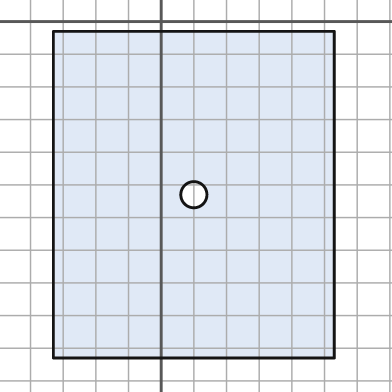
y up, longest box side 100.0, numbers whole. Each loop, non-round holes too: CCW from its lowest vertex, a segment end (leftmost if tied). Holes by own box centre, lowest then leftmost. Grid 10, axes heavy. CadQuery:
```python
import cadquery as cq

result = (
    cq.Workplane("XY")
    .moveTo(-33.0, -103.0)
    .lineTo(53.0, -103.0)
    .lineTo(53.0, -3.0)
    .lineTo(-33.0, -3.0)
    .close()
    .moveTo(10.0, -53.0)
    .circle(4.0)
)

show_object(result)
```